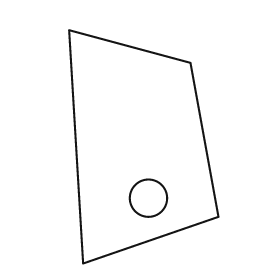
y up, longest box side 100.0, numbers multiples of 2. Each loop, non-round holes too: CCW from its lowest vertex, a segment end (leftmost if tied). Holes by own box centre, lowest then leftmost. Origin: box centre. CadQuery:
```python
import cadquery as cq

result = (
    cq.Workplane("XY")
    .moveTo(-26.0, -50.0)
    .lineTo(32.0, -30.0)
    .lineTo(20.0, 36.0)
    .lineTo(-32.0, 50.0)
    .close()
    .moveTo(2.0, -22.0)
    .circle(8.0)
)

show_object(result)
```